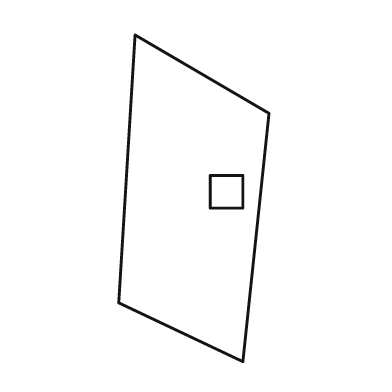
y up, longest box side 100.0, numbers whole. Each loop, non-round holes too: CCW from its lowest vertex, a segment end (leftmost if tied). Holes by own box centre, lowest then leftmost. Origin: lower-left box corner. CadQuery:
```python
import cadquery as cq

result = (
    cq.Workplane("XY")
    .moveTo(38.0, 0.0)
    .lineTo(46.0, 76.0)
    .lineTo(5.0, 100.0)
    .lineTo(0.0, 18.0)
    .close()
    .moveTo(28.0, 47.0)
    .lineTo(38.0, 47.0)
    .lineTo(38.0, 57.0)
    .lineTo(28.0, 57.0)
    .close()
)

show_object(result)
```